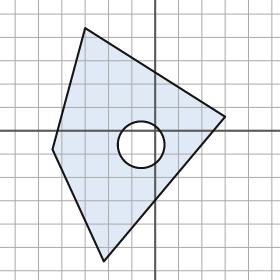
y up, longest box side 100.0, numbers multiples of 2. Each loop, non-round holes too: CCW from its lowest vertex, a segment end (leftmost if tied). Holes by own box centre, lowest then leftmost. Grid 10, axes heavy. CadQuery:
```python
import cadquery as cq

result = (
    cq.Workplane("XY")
    .moveTo(-22.0, -56.0)
    .lineTo(30.0, 6.0)
    .lineTo(-30.0, 44.0)
    .lineTo(-44.0, -8.0)
    .close()
    .moveTo(-6.0, -6.0)
    .circle(10.0)
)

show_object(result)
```